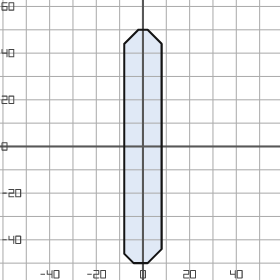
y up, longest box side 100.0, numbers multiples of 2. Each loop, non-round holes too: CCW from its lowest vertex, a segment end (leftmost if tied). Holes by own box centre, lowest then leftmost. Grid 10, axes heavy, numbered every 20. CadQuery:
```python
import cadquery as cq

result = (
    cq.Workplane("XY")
    .moveTo(-4.0, -50.0)
    .lineTo(2.0, -50.0)
    .lineTo(8.0, -44.0)
    .lineTo(8.0, 44.0)
    .lineTo(2.0, 50.0)
    .lineTo(-2.0, 50.0)
    .lineTo(-8.0, 44.0)
    .lineTo(-8.0, -46.0)
    .close()
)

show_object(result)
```